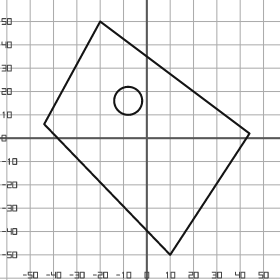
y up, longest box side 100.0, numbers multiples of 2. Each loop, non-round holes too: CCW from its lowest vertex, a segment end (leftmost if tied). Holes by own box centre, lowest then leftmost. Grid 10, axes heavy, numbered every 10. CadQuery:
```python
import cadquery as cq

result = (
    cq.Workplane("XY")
    .moveTo(10.0, -50.0)
    .lineTo(44.0, 2.0)
    .lineTo(-20.0, 50.0)
    .lineTo(-44.0, 6.0)
    .close()
    .moveTo(-8.0, 16.0)
    .circle(6.0)
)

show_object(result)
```